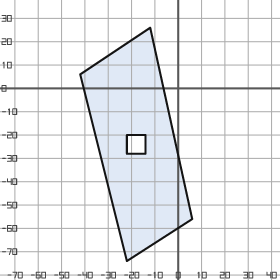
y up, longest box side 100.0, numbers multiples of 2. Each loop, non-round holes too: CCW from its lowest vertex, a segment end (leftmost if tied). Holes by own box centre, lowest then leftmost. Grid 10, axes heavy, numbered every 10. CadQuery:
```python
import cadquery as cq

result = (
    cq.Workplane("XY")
    .moveTo(-22.0, -74.0)
    .lineTo(6.0, -56.0)
    .lineTo(-12.0, 26.0)
    .lineTo(-42.0, 6.0)
    .close()
    .moveTo(-22.0, -28.0)
    .lineTo(-14.0, -28.0)
    .lineTo(-14.0, -20.0)
    .lineTo(-22.0, -20.0)
    .close()
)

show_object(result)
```